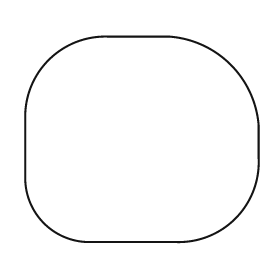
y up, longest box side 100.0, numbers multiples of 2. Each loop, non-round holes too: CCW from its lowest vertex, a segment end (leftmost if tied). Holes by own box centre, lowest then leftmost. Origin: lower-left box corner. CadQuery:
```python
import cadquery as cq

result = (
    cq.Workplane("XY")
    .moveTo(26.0, 0.0)
    .lineTo(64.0, 0.0)
    .threePointArc((90.0, 10.0), (100.0, 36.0))
    .lineTo(100.0, 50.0)
    .threePointArc((88.0, 76.0), (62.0, 88.0))
    .lineTo(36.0, 88.0)
    .threePointArc((10.0, 78.0), (0.0, 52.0))
    .lineTo(0.0, 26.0)
    .threePointArc((8.0, 8.0), (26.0, 0.0))
    .close()
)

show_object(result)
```